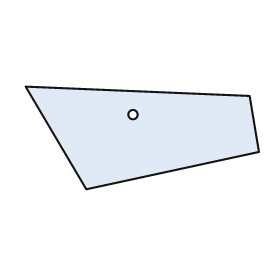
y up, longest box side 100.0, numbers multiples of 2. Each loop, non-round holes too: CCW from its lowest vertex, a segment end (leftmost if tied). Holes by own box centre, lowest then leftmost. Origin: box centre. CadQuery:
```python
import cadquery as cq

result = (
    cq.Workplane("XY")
    .moveTo(-24.0, -22.0)
    .lineTo(50.0, -6.0)
    .lineTo(46.0, 18.0)
    .lineTo(-50.0, 22.0)
    .close()
    .moveTo(-4.0, 10.0)
    .circle(2.0)
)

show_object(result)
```